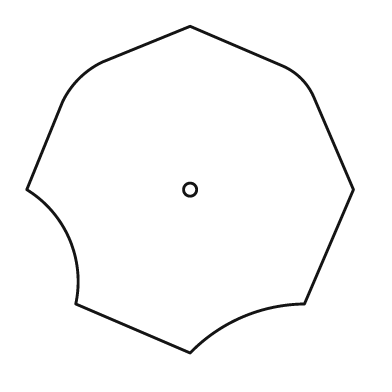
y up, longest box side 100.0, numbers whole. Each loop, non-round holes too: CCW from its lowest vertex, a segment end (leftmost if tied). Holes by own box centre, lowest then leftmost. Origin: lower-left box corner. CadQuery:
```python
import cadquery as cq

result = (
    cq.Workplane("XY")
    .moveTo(50.0, 0.0)
    .threePointArc((66.0, 11.0), (85.0, 15.0))
    .lineTo(100.0, 50.0)
    .lineTo(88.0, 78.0)
    .threePointArc((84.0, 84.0), (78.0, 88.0))
    .lineTo(50.0, 100.0)
    .lineTo(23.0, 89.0)
    .threePointArc((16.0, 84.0), (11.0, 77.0))
    .lineTo(0.0, 50.0)
    .threePointArc((13.0, 35.0), (15.0, 15.0))
    .close()
    .moveTo(50.0, 50.0)
    .circle(2.0)
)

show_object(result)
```